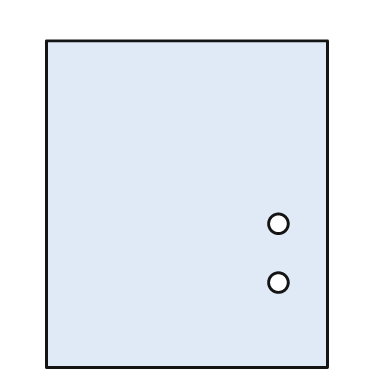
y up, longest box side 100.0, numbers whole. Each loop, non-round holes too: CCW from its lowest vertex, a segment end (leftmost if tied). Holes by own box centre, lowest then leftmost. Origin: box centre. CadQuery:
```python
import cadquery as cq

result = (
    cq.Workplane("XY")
    .moveTo(-43.0, -50.0)
    .lineTo(43.0, -50.0)
    .lineTo(43.0, 50.0)
    .lineTo(-43.0, 50.0)
    .close()
    .moveTo(28.0, -24.0)
    .circle(3.0)
    .moveTo(28.0, -6.0)
    .circle(3.0)
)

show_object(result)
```